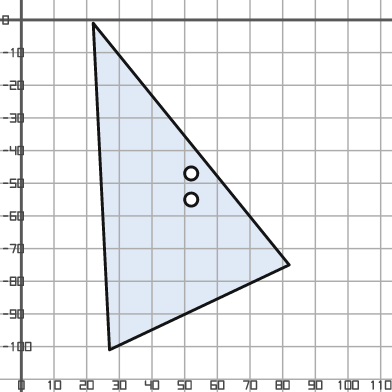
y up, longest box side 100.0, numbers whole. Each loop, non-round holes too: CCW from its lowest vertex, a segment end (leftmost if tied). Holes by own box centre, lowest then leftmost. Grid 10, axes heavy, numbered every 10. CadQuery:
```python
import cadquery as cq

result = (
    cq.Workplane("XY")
    .moveTo(27.0, -101.0)
    .lineTo(82.0, -75.0)
    .lineTo(22.0, -1.0)
    .close()
    .moveTo(52.0, -55.0)
    .circle(2.0)
    .moveTo(52.0, -47.0)
    .circle(2.0)
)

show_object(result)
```